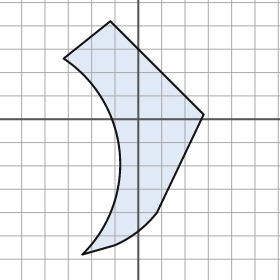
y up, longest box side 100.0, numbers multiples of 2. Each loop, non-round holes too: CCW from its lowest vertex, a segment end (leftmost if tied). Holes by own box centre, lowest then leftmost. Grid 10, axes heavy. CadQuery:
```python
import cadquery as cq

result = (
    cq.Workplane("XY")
    .moveTo(-24.0, -58.0)
    .lineTo(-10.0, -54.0)
    .threePointArc((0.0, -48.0), (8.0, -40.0))
    .lineTo(28.0, 2.0)
    .lineTo(-12.0, 42.0)
    .lineTo(-32.0, 26.0)
    .threePointArc((-8.0, -14.0), (-24.0, -58.0))
    .close()
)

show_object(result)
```